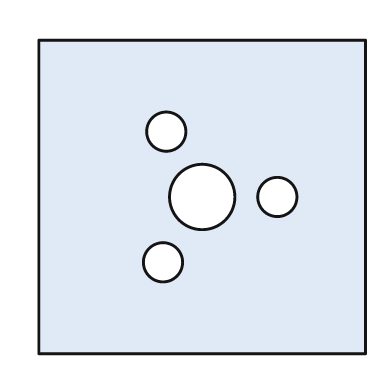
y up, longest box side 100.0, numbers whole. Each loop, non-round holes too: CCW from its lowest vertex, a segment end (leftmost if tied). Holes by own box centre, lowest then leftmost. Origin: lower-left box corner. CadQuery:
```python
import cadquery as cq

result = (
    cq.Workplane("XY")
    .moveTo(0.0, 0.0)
    .lineTo(100.0, 0.0)
    .lineTo(100.0, 96.0)
    .lineTo(0.0, 96.0)
    .close()
    .moveTo(38.0, 28.0)
    .circle(6.0)
    .moveTo(50.0, 48.0)
    .circle(10.0)
    .moveTo(73.0, 48.0)
    .circle(6.0)
    .moveTo(39.0, 68.0)
    .circle(6.0)
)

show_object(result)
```